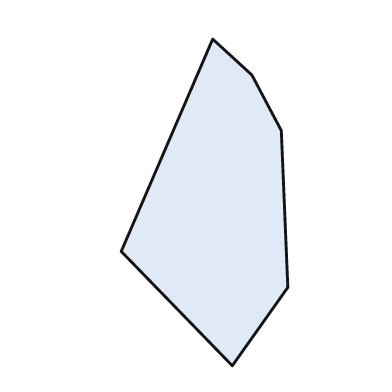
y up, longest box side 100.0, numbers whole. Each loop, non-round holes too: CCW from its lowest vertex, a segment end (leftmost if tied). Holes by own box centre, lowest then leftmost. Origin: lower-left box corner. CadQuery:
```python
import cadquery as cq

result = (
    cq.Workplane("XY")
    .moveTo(34.0, 0.0)
    .lineTo(51.0, 24.0)
    .lineTo(49.0, 72.0)
    .lineTo(40.0, 89.0)
    .lineTo(28.0, 100.0)
    .lineTo(0.0, 35.0)
    .close()
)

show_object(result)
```